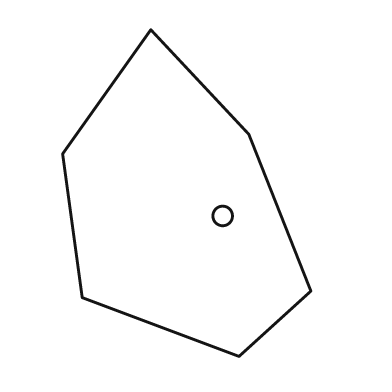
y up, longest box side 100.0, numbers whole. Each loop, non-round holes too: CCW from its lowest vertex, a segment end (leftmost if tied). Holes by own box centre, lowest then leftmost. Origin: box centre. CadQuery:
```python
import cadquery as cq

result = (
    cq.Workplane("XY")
    .moveTo(16.0, -50.0)
    .lineTo(38.0, -30.0)
    .lineTo(19.0, 18.0)
    .lineTo(-11.0, 50.0)
    .lineTo(-38.0, 12.0)
    .lineTo(-32.0, -32.0)
    .close()
    .moveTo(11.0, -7.0)
    .circle(3.0)
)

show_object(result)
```